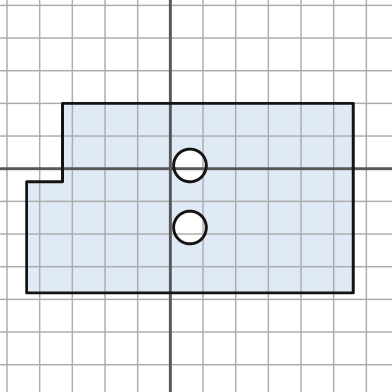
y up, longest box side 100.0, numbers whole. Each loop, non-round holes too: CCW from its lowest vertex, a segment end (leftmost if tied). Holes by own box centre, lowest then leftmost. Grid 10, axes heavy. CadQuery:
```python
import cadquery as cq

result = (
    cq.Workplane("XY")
    .moveTo(-44.0, -38.0)
    .lineTo(56.0, -38.0)
    .lineTo(56.0, 20.0)
    .lineTo(-33.0, 20.0)
    .lineTo(-33.0, -4.0)
    .lineTo(-44.0, -4.0)
    .close()
    .moveTo(6.0, -18.0)
    .circle(5.0)
    .moveTo(6.0, 1.0)
    .circle(5.0)
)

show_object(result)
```